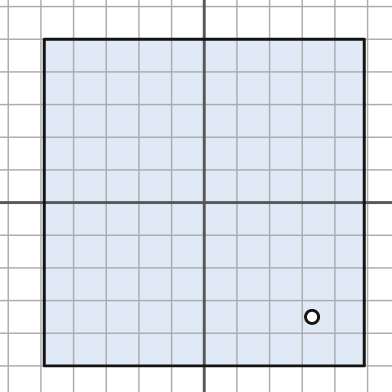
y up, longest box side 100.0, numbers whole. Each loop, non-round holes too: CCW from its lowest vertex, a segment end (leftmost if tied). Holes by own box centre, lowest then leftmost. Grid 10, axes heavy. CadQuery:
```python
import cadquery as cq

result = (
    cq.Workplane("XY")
    .moveTo(-49.0, -50.0)
    .lineTo(49.0, -50.0)
    .lineTo(49.0, 50.0)
    .lineTo(-49.0, 50.0)
    .close()
    .moveTo(33.0, -35.0)
    .circle(2.0)
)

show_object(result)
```